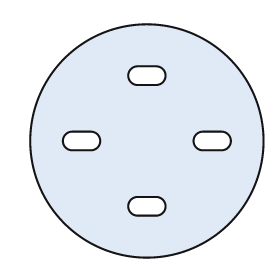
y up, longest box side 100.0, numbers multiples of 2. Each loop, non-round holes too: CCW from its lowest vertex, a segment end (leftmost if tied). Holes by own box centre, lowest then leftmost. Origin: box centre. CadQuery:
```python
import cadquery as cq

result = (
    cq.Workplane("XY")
    .moveTo(0.0, 0.0)
    .circle(50.0)
    .moveTo(-4.0, -32.0)
    .lineTo(4.0, -32.0)
    .threePointArc((8.0, -28.0), (4.0, -24.0))
    .lineTo(-4.0, -24.0)
    .threePointArc((-8.0, -28.0), (-4.0, -32.0))
    .close()
    .moveTo(-32.0, -4.0)
    .lineTo(-24.0, -4.0)
    .threePointArc((-20.0, 0.0), (-24.0, 4.0))
    .lineTo(-32.0, 4.0)
    .threePointArc((-36.0, 0.0), (-32.0, -4.0))
    .close()
    .moveTo(24.0, -4.0)
    .lineTo(32.0, -4.0)
    .threePointArc((36.0, 0.0), (32.0, 4.0))
    .lineTo(24.0, 4.0)
    .threePointArc((20.0, 0.0), (24.0, -4.0))
    .close()
    .moveTo(-4.0, 24.0)
    .lineTo(4.0, 24.0)
    .threePointArc((8.0, 28.0), (4.0, 32.0))
    .lineTo(-4.0, 32.0)
    .threePointArc((-8.0, 28.0), (-4.0, 24.0))
    .close()
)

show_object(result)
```